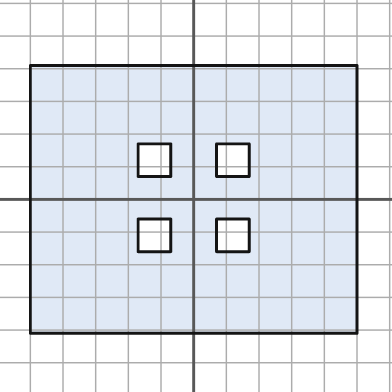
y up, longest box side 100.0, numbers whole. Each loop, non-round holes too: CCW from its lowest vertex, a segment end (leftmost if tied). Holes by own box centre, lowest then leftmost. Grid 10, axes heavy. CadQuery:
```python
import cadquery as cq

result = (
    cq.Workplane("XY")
    .moveTo(-50.0, -41.0)
    .lineTo(50.0, -41.0)
    .lineTo(50.0, 41.0)
    .lineTo(-50.0, 41.0)
    .close()
    .moveTo(-17.0, -16.0)
    .lineTo(-7.0, -16.0)
    .lineTo(-7.0, -6.0)
    .lineTo(-17.0, -6.0)
    .close()
    .moveTo(7.0, -16.0)
    .lineTo(17.0, -16.0)
    .lineTo(17.0, -6.0)
    .lineTo(7.0, -6.0)
    .close()
    .moveTo(-17.0, 7.0)
    .lineTo(-7.0, 7.0)
    .lineTo(-7.0, 17.0)
    .lineTo(-17.0, 17.0)
    .close()
    .moveTo(7.0, 7.0)
    .lineTo(17.0, 7.0)
    .lineTo(17.0, 17.0)
    .lineTo(7.0, 17.0)
    .close()
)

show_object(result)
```